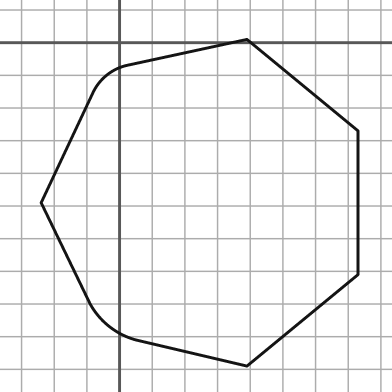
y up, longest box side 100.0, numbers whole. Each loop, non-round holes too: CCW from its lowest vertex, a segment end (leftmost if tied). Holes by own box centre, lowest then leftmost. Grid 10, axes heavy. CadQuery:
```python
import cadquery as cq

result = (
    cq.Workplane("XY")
    .moveTo(39.0, -99.0)
    .lineTo(73.0, -71.0)
    .lineTo(73.0, -27.0)
    .lineTo(39.0, 1.0)
    .lineTo(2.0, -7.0)
    .threePointArc((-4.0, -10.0), (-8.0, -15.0))
    .lineTo(-24.0, -49.0)
    .lineTo(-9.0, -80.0)
    .threePointArc((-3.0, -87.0), (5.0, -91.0))
    .close()
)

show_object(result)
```